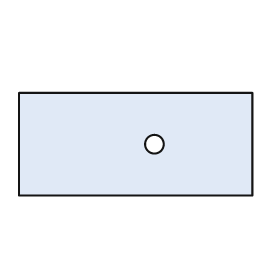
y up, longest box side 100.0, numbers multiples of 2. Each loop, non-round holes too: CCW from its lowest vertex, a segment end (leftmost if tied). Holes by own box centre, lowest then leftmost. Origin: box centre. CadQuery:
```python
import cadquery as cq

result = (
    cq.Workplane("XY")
    .moveTo(-50.0, -22.0)
    .lineTo(50.0, -22.0)
    .lineTo(50.0, 22.0)
    .lineTo(-50.0, 22.0)
    .close()
    .moveTo(8.0, 0.0)
    .circle(4.0)
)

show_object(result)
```